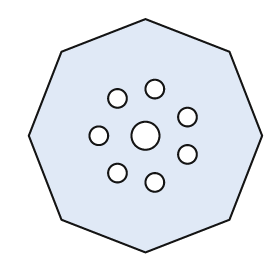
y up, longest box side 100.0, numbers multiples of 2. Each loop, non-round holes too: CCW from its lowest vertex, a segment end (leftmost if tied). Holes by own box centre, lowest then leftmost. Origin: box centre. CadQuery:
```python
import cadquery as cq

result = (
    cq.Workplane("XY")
    .moveTo(0.0, -50.0)
    .lineTo(36.0, -36.0)
    .lineTo(50.0, 0.0)
    .lineTo(36.0, 36.0)
    .lineTo(0.0, 50.0)
    .lineTo(-36.0, 36.0)
    .lineTo(-50.0, 0.0)
    .lineTo(-36.0, -36.0)
    .close()
    .moveTo(4.0, -20.0)
    .circle(4.0)
    .moveTo(-12.0, -16.0)
    .circle(4.0)
    .moveTo(18.0, -8.0)
    .circle(4.0)
    .moveTo(-20.0, 0.0)
    .circle(4.0)
    .moveTo(0.0, 0.0)
    .circle(6.0)
    .moveTo(18.0, 8.0)
    .circle(4.0)
    .moveTo(-12.0, 16.0)
    .circle(4.0)
    .moveTo(4.0, 20.0)
    .circle(4.0)
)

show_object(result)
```